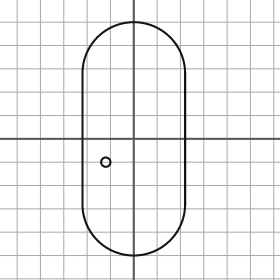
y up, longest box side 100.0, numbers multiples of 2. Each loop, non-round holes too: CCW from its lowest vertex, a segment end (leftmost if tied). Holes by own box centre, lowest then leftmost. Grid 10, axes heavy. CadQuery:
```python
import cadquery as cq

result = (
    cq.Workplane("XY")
    .moveTo(-22.0, -28.0)
    .threePointArc((0.0, -50.0), (22.0, -28.0))
    .lineTo(22.0, 28.0)
    .threePointArc((0.0, 50.0), (-22.0, 28.0))
    .close()
    .moveTo(-12.0, -10.0)
    .circle(2.0)
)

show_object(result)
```